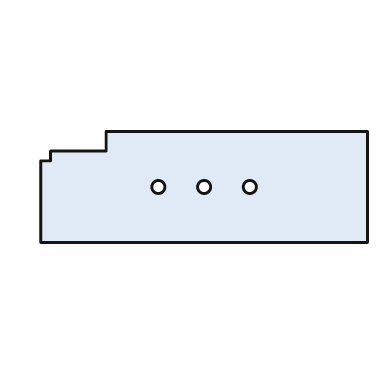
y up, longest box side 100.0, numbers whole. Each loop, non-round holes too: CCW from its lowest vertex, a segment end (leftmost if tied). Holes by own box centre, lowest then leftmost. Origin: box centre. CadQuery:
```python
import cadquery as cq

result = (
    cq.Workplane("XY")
    .moveTo(-50.0, -17.0)
    .lineTo(50.0, -17.0)
    .lineTo(50.0, 17.0)
    .lineTo(-30.0, 17.0)
    .lineTo(-30.0, 11.0)
    .lineTo(-47.0, 11.0)
    .lineTo(-47.0, 8.0)
    .lineTo(-50.0, 8.0)
    .close()
    .moveTo(-14.0, 0.0)
    .circle(2.0)
    .moveTo(0.0, 0.0)
    .circle(2.0)
    .moveTo(14.0, 0.0)
    .circle(2.0)
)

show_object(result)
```